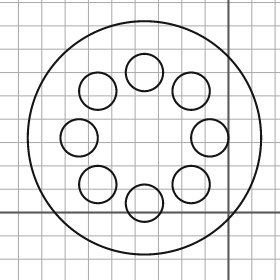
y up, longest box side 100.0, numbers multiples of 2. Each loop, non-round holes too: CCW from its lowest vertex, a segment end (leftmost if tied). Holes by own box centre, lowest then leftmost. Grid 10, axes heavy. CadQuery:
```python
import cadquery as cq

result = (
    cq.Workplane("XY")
    .moveTo(-36.0, 32.0)
    .circle(50.0)
    .moveTo(-36.0, 4.0)
    .circle(8.0)
    .moveTo(-56.0, 12.0)
    .circle(8.0)
    .moveTo(-16.0, 12.0)
    .circle(8.0)
    .moveTo(-64.0, 32.0)
    .circle(8.0)
    .moveTo(-8.0, 32.0)
    .circle(8.0)
    .moveTo(-56.0, 52.0)
    .circle(8.0)
    .moveTo(-16.0, 52.0)
    .circle(8.0)
    .moveTo(-36.0, 60.0)
    .circle(8.0)
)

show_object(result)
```